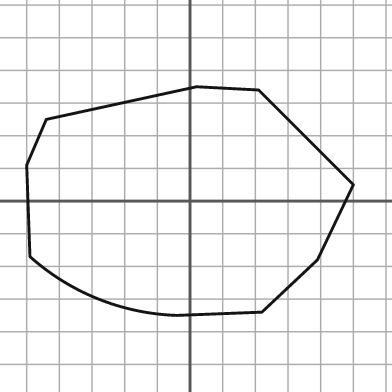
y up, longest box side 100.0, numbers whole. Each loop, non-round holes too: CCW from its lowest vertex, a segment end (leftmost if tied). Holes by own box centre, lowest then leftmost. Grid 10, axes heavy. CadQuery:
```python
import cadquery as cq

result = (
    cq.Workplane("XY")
    .moveTo(-4.0, -35.0)
    .lineTo(22.0, -34.0)
    .lineTo(39.0, -18.0)
    .lineTo(50.0, 5.0)
    .lineTo(21.0, 34.0)
    .lineTo(2.0, 35.0)
    .lineTo(-44.0, 25.0)
    .lineTo(-50.0, 11.0)
    .lineTo(-49.0, -17.0)
    .threePointArc((-28.0, -30.0), (-4.0, -35.0))
    .close()
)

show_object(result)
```